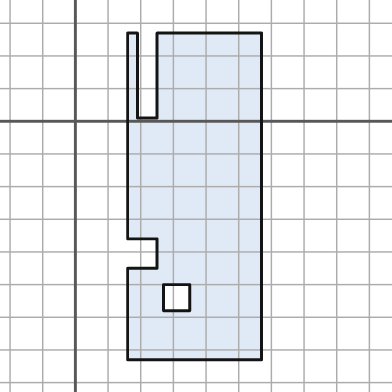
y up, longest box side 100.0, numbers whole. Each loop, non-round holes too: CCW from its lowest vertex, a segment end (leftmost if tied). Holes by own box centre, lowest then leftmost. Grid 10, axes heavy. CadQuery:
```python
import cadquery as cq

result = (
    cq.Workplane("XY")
    .moveTo(16.0, -73.0)
    .lineTo(57.0, -73.0)
    .lineTo(57.0, 27.0)
    .lineTo(25.0, 27.0)
    .lineTo(25.0, 1.0)
    .lineTo(19.0, 1.0)
    .lineTo(19.0, 27.0)
    .lineTo(16.0, 27.0)
    .lineTo(16.0, -36.0)
    .lineTo(25.0, -36.0)
    .lineTo(25.0, -45.0)
    .lineTo(16.0, -45.0)
    .close()
    .moveTo(27.0, -58.0)
    .lineTo(35.0, -58.0)
    .lineTo(35.0, -50.0)
    .lineTo(27.0, -50.0)
    .close()
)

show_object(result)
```